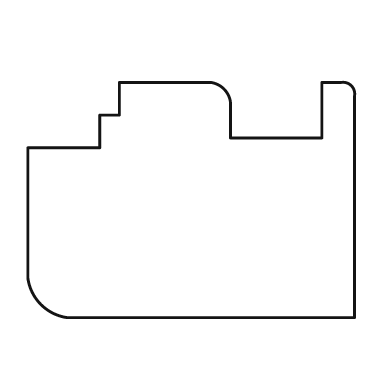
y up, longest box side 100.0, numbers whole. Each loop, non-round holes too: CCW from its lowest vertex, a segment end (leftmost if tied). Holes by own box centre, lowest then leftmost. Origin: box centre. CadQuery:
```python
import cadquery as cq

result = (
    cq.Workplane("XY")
    .moveTo(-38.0, -36.0)
    .lineTo(50.0, -36.0)
    .lineTo(50.0, 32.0)
    .threePointArc((49.0, 35.0), (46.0, 36.0))
    .lineTo(40.0, 36.0)
    .lineTo(40.0, 19.0)
    .lineTo(12.0, 19.0)
    .lineTo(12.0, 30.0)
    .threePointArc((10.0, 34.0), (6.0, 36.0))
    .lineTo(-22.0, 36.0)
    .lineTo(-22.0, 26.0)
    .lineTo(-28.0, 26.0)
    .lineTo(-28.0, 16.0)
    .lineTo(-50.0, 16.0)
    .lineTo(-50.0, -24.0)
    .threePointArc((-46.0, -32.0), (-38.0, -36.0))
    .close()
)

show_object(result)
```